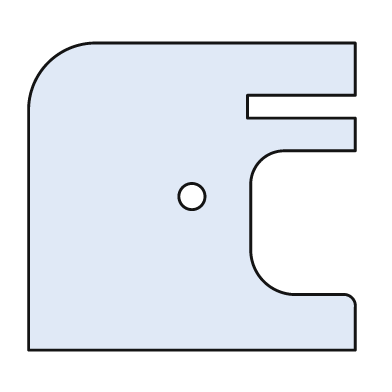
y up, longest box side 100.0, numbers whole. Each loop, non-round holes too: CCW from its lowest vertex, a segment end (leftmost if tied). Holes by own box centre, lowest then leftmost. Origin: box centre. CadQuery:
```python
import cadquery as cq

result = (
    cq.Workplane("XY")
    .moveTo(-50.0, -47.0)
    .lineTo(50.0, -47.0)
    .lineTo(50.0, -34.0)
    .threePointArc((49.0, -31.0), (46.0, -30.0))
    .lineTo(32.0, -30.0)
    .threePointArc((22.0, -26.0), (18.0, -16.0))
    .lineTo(18.0, 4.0)
    .threePointArc((21.0, 11.0), (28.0, 14.0))
    .lineTo(50.0, 14.0)
    .lineTo(50.0, 24.0)
    .lineTo(17.0, 24.0)
    .lineTo(17.0, 31.0)
    .lineTo(50.0, 31.0)
    .lineTo(50.0, 47.0)
    .lineTo(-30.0, 47.0)
    .threePointArc((-44.0, 41.0), (-50.0, 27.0))
    .close()
    .moveTo(0.0, 0.0)
    .circle(4.0)
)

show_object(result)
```